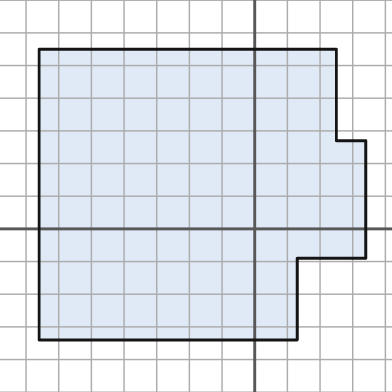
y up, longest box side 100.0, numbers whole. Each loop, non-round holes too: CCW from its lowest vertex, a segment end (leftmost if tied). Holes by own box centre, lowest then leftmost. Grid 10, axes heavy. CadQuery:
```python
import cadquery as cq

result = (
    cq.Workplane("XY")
    .moveTo(-66.0, -34.0)
    .lineTo(13.0, -34.0)
    .lineTo(13.0, -9.0)
    .lineTo(34.0, -9.0)
    .lineTo(34.0, 27.0)
    .lineTo(25.0, 27.0)
    .lineTo(25.0, 55.0)
    .lineTo(-66.0, 55.0)
    .close()
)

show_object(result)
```